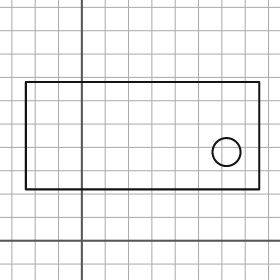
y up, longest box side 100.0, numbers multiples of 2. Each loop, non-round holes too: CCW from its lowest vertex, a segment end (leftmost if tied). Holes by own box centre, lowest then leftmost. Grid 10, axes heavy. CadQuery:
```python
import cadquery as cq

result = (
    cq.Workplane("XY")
    .moveTo(-24.0, 22.0)
    .lineTo(76.0, 22.0)
    .lineTo(76.0, 68.0)
    .lineTo(-24.0, 68.0)
    .close()
    .moveTo(62.0, 38.0)
    .circle(6.0)
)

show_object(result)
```